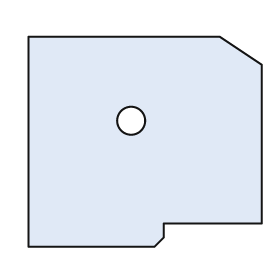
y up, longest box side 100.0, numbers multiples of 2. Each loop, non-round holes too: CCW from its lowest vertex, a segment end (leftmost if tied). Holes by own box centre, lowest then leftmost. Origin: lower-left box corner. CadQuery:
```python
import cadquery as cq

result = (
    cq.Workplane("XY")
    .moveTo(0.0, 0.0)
    .lineTo(54.0, 0.0)
    .lineTo(58.0, 4.0)
    .lineTo(58.0, 10.0)
    .lineTo(100.0, 10.0)
    .lineTo(100.0, 78.0)
    .lineTo(82.0, 90.0)
    .lineTo(0.0, 90.0)
    .close()
    .moveTo(44.0, 54.0)
    .circle(6.0)
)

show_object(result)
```